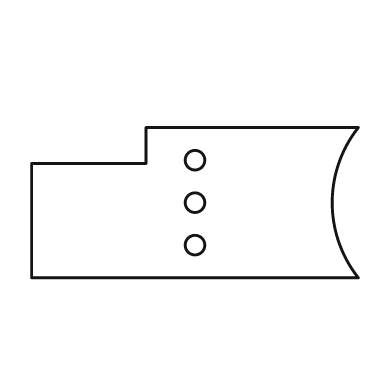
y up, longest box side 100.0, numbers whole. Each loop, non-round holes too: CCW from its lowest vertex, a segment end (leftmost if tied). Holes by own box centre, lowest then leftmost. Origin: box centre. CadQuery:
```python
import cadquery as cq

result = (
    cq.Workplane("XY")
    .moveTo(-50.0, -23.0)
    .lineTo(50.0, -23.0)
    .threePointArc((42.0, 0.0), (50.0, 23.0))
    .lineTo(-15.0, 23.0)
    .lineTo(-15.0, 12.0)
    .lineTo(-50.0, 12.0)
    .close()
    .moveTo(0.0, -13.0)
    .circle(3.0)
    .moveTo(0.0, 0.0)
    .circle(3.0)
    .moveTo(0.0, 13.0)
    .circle(3.0)
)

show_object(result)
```